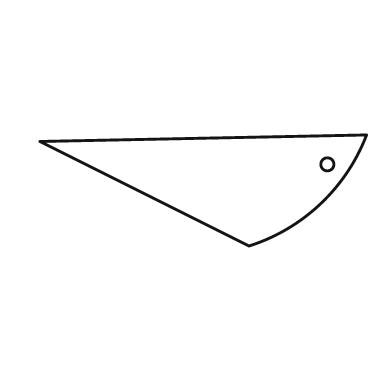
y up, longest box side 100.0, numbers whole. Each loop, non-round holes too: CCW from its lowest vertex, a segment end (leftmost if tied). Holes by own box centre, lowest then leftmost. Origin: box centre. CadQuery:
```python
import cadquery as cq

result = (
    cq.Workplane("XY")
    .moveTo(14.0, -17.0)
    .threePointArc((36.0, -4.0), (50.0, 17.0))
    .lineTo(-50.0, 15.0)
    .close()
    .moveTo(38.0, 8.0)
    .circle(2.0)
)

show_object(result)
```